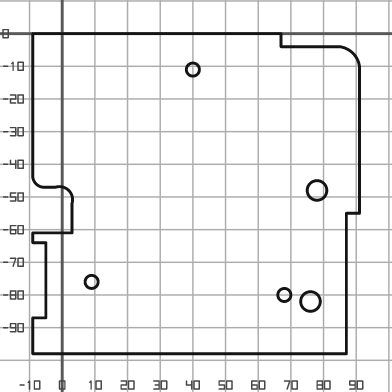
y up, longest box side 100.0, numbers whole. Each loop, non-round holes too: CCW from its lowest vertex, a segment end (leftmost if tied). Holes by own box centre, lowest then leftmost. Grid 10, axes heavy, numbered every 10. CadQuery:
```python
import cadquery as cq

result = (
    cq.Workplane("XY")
    .moveTo(-9.0, -98.0)
    .lineTo(87.0, -98.0)
    .lineTo(87.0, -55.0)
    .lineTo(91.0, -55.0)
    .lineTo(91.0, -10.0)
    .threePointArc((89.0, -6.0), (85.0, -4.0))
    .lineTo(67.0, -4.0)
    .lineTo(67.0, 0.0)
    .lineTo(-9.0, 0.0)
    .lineTo(-9.0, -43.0)
    .threePointArc((-8.0, -46.0), (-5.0, -47.0))
    .lineTo(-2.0, -47.0)
    .threePointArc((2.0, -48.0), (3.0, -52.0))
    .lineTo(3.0, -61.0)
    .lineTo(-9.0, -61.0)
    .lineTo(-9.0, -64.0)
    .lineTo(-5.0, -64.0)
    .lineTo(-5.0, -87.0)
    .lineTo(-9.0, -87.0)
    .close()
    .moveTo(76.0, -82.0)
    .circle(3.0)
    .moveTo(68.0, -80.0)
    .circle(2.0)
    .moveTo(9.0, -76.0)
    .circle(2.0)
    .moveTo(78.0, -48.0)
    .circle(3.0)
    .moveTo(40.0, -11.0)
    .circle(2.0)
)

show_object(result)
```